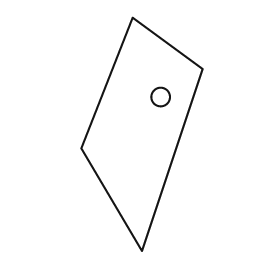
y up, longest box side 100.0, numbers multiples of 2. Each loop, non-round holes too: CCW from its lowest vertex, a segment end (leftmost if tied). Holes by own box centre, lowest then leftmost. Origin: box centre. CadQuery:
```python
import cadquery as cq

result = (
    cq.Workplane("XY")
    .moveTo(0.0, -50.0)
    .lineTo(26.0, 28.0)
    .lineTo(-4.0, 50.0)
    .lineTo(-26.0, -6.0)
    .close()
    .moveTo(8.0, 16.0)
    .circle(4.0)
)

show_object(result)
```